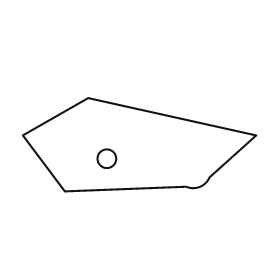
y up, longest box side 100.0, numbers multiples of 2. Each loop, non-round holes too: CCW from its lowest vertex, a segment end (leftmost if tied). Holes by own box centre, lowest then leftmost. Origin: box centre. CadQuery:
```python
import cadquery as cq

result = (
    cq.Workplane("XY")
    .moveTo(-32.0, -20.0)
    .lineTo(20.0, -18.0)
    .threePointArc((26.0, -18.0), (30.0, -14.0))
    .lineTo(50.0, 4.0)
    .lineTo(-22.0, 20.0)
    .lineTo(-50.0, 4.0)
    .close()
    .moveTo(-14.0, -6.0)
    .circle(4.0)
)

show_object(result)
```